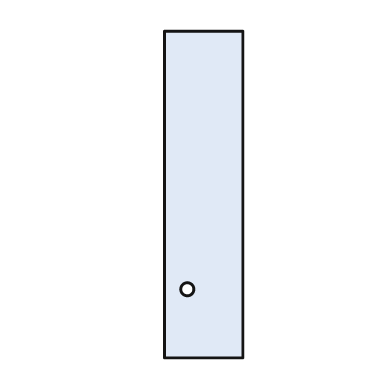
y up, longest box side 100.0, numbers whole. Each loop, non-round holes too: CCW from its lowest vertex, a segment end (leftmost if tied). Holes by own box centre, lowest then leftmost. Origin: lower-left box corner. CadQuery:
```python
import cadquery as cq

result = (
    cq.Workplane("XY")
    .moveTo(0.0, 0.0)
    .lineTo(24.0, 0.0)
    .lineTo(24.0, 100.0)
    .lineTo(0.0, 100.0)
    .close()
    .moveTo(7.0, 21.0)
    .circle(2.0)
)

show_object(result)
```